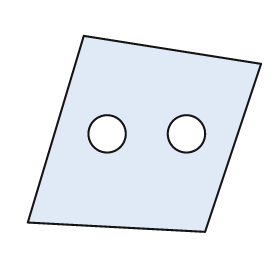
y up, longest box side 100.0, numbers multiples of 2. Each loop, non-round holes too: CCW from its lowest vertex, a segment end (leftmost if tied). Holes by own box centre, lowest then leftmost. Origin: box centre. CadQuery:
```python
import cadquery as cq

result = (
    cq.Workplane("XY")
    .moveTo(26.0, -42.0)
    .lineTo(50.0, 30.0)
    .lineTo(-26.0, 42.0)
    .lineTo(-50.0, -38.0)
    .close()
    .moveTo(-16.0, 0.0)
    .circle(8.0)
    .moveTo(18.0, 0.0)
    .circle(8.0)
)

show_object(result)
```